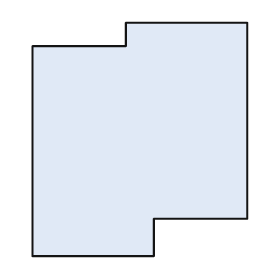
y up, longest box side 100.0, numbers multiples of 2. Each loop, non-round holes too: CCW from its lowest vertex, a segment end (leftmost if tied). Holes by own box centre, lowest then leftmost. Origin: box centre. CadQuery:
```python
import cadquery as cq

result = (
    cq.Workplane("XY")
    .moveTo(-46.0, -50.0)
    .lineTo(6.0, -50.0)
    .lineTo(6.0, -34.0)
    .lineTo(46.0, -34.0)
    .lineTo(46.0, 50.0)
    .lineTo(-6.0, 50.0)
    .lineTo(-6.0, 40.0)
    .lineTo(-46.0, 40.0)
    .close()
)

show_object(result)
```